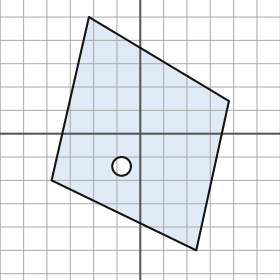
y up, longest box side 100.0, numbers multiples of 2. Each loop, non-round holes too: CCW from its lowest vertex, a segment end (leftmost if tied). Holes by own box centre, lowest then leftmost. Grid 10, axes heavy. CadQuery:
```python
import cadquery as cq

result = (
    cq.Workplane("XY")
    .moveTo(24.0, -50.0)
    .lineTo(38.0, 14.0)
    .lineTo(-22.0, 50.0)
    .lineTo(-38.0, -20.0)
    .close()
    .moveTo(-8.0, -14.0)
    .circle(4.0)
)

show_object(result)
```